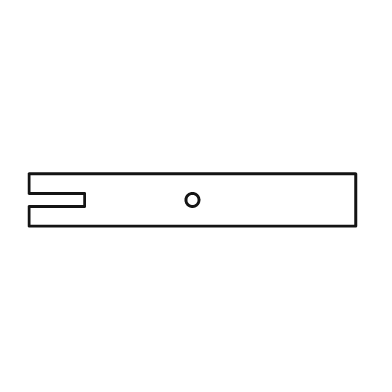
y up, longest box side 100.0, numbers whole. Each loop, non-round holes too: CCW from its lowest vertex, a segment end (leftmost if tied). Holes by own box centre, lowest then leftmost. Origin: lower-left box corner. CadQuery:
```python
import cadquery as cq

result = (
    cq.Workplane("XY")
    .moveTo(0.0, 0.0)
    .lineTo(100.0, 0.0)
    .lineTo(100.0, 16.0)
    .lineTo(0.0, 16.0)
    .lineTo(0.0, 10.0)
    .lineTo(17.0, 10.0)
    .lineTo(17.0, 6.0)
    .lineTo(0.0, 6.0)
    .close()
    .moveTo(50.0, 8.0)
    .circle(2.0)
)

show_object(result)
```